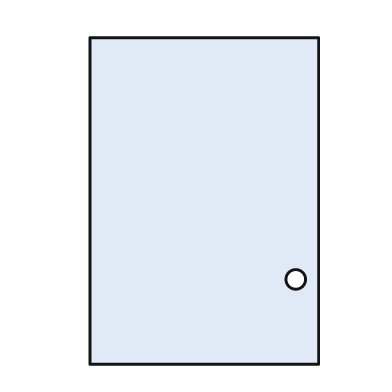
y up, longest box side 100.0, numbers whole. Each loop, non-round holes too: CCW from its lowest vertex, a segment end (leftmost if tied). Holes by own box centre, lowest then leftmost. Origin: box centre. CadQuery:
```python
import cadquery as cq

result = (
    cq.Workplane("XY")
    .moveTo(-35.0, -50.0)
    .lineTo(35.0, -50.0)
    .lineTo(35.0, 50.0)
    .lineTo(-35.0, 50.0)
    .close()
    .moveTo(28.0, -24.0)
    .circle(3.0)
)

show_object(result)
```